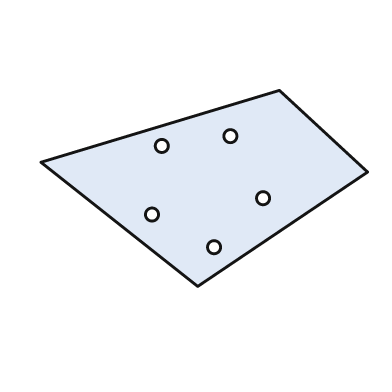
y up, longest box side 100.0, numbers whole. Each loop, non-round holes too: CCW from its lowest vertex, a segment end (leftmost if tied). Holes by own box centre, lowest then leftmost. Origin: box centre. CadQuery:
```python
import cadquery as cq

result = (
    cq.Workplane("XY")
    .moveTo(-2.0, -30.0)
    .lineTo(50.0, 5.0)
    .lineTo(23.0, 30.0)
    .lineTo(-50.0, 8.0)
    .close()
    .moveTo(3.0, -18.0)
    .circle(2.0)
    .moveTo(-16.0, -8.0)
    .circle(2.0)
    .moveTo(18.0, -3.0)
    .circle(2.0)
    .moveTo(-13.0, 13.0)
    .circle(2.0)
    .moveTo(8.0, 16.0)
    .circle(2.0)
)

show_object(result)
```